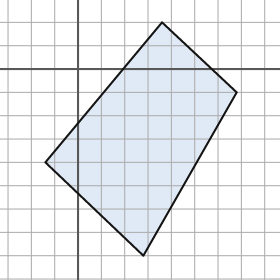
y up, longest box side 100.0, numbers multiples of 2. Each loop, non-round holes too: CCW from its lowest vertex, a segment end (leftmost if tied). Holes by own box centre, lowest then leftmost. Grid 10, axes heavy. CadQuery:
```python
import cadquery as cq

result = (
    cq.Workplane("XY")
    .moveTo(28.0, -80.0)
    .lineTo(68.0, -10.0)
    .lineTo(36.0, 20.0)
    .lineTo(-14.0, -40.0)
    .close()
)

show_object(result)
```